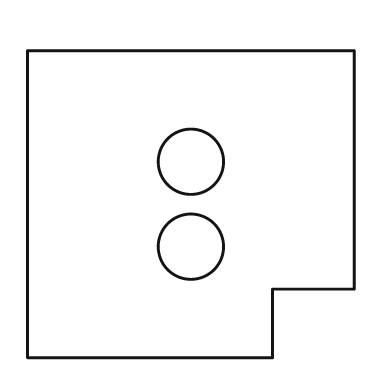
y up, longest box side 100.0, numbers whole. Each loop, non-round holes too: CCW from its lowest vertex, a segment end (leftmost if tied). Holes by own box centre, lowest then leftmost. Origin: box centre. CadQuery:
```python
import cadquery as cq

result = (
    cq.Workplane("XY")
    .moveTo(-50.0, -47.0)
    .lineTo(25.0, -47.0)
    .lineTo(25.0, -26.0)
    .lineTo(50.0, -26.0)
    .lineTo(50.0, 47.0)
    .lineTo(-50.0, 47.0)
    .close()
    .moveTo(0.0, -13.0)
    .circle(10.0)
    .moveTo(0.0, 13.0)
    .circle(10.0)
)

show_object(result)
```